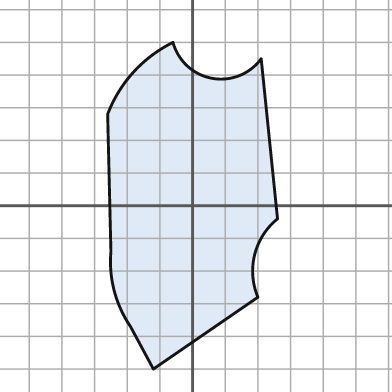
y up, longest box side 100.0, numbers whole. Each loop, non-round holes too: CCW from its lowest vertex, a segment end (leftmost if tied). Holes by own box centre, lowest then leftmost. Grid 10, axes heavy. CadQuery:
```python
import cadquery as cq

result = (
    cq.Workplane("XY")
    .moveTo(-12.0, -50.0)
    .lineTo(20.0, -28.0)
    .threePointArc((19.0, -15.0), (26.0, -4.0))
    .lineTo(21.0, 45.0)
    .threePointArc((6.0, 39.0), (-6.0, 50.0))
    .threePointArc((-18.0, 41.0), (-26.0, 28.0))
    .lineTo(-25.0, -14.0)
    .threePointArc((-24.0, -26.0), (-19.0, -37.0))
    .close()
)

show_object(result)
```